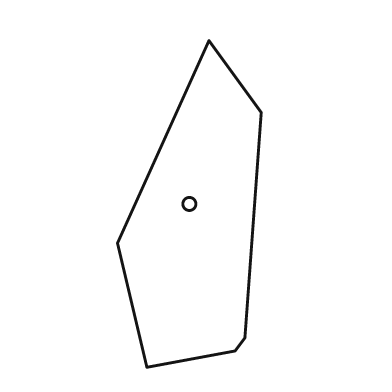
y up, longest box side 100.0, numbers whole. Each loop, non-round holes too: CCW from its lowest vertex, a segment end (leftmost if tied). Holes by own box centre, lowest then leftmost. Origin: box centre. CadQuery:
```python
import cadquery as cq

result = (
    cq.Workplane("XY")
    .moveTo(-13.0, -50.0)
    .lineTo(14.0, -45.0)
    .lineTo(17.0, -41.0)
    .lineTo(22.0, 28.0)
    .lineTo(6.0, 50.0)
    .lineTo(-22.0, -12.0)
    .close()
    .moveTo(0.0, 0.0)
    .circle(2.0)
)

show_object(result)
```